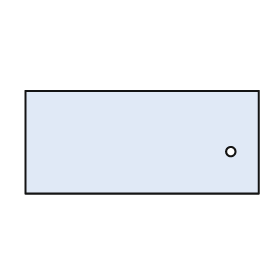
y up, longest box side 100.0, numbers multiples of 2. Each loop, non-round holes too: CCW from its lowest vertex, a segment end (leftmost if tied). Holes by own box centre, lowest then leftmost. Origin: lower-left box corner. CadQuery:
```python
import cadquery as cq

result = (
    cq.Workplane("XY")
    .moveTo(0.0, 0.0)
    .lineTo(100.0, 0.0)
    .lineTo(100.0, 44.0)
    .lineTo(0.0, 44.0)
    .close()
    .moveTo(88.0, 18.0)
    .circle(2.0)
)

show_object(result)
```